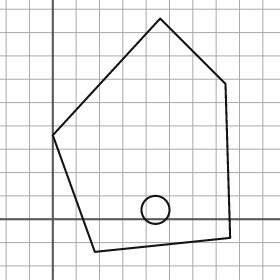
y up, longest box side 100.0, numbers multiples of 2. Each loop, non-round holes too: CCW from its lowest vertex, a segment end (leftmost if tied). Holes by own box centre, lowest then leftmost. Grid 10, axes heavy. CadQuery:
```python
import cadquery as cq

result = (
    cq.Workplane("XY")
    .moveTo(18.0, -14.0)
    .lineTo(76.0, -8.0)
    .lineTo(74.0, 58.0)
    .lineTo(46.0, 86.0)
    .lineTo(0.0, 36.0)
    .close()
    .moveTo(44.0, 4.0)
    .circle(6.0)
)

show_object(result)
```